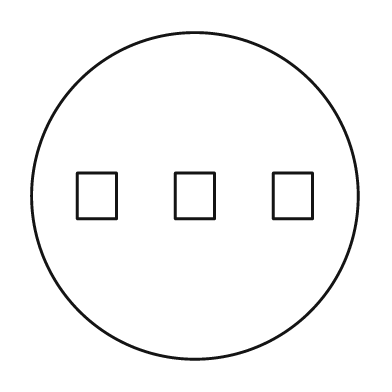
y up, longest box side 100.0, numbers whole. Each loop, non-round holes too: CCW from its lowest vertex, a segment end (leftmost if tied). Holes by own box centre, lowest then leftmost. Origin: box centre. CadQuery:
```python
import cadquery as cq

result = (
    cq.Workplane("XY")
    .moveTo(0.0, 0.0)
    .circle(50.0)
    .moveTo(-36.0, -7.0)
    .lineTo(-24.0, -7.0)
    .lineTo(-24.0, 7.0)
    .lineTo(-36.0, 7.0)
    .close()
    .moveTo(-6.0, -7.0)
    .lineTo(6.0, -7.0)
    .lineTo(6.0, 7.0)
    .lineTo(-6.0, 7.0)
    .close()
    .moveTo(24.0, -7.0)
    .lineTo(36.0, -7.0)
    .lineTo(36.0, 7.0)
    .lineTo(24.0, 7.0)
    .close()
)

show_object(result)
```